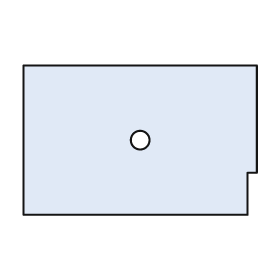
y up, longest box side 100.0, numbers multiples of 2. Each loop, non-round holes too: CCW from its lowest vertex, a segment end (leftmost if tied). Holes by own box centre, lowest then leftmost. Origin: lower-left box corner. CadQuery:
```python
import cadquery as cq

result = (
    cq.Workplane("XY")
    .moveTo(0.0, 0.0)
    .lineTo(96.0, 0.0)
    .lineTo(96.0, 18.0)
    .lineTo(100.0, 18.0)
    .lineTo(100.0, 64.0)
    .lineTo(0.0, 64.0)
    .close()
    .moveTo(50.0, 32.0)
    .circle(4.0)
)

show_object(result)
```